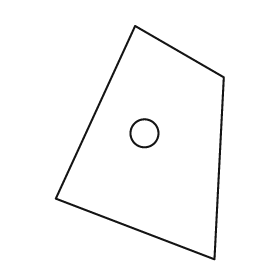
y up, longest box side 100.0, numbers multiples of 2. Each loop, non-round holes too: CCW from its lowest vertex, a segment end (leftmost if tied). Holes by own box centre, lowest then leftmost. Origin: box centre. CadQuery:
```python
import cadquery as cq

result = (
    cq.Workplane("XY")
    .moveTo(32.0, -50.0)
    .lineTo(36.0, 28.0)
    .lineTo(-2.0, 50.0)
    .lineTo(-36.0, -24.0)
    .close()
    .moveTo(2.0, 4.0)
    .circle(6.0)
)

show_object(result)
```